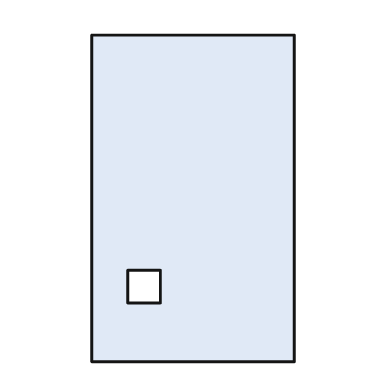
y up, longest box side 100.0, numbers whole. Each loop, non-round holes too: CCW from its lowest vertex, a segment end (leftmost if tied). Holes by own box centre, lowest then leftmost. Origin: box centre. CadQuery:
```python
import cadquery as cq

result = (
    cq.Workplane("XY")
    .moveTo(-31.0, -50.0)
    .lineTo(31.0, -50.0)
    .lineTo(31.0, 50.0)
    .lineTo(-31.0, 50.0)
    .close()
    .moveTo(-20.0, -32.0)
    .lineTo(-10.0, -32.0)
    .lineTo(-10.0, -22.0)
    .lineTo(-20.0, -22.0)
    .close()
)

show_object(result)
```